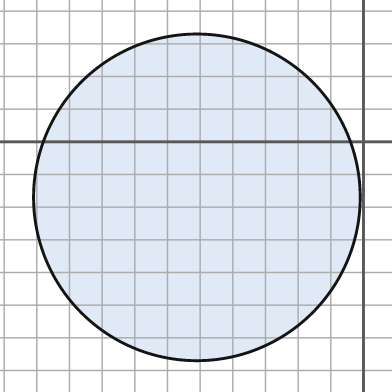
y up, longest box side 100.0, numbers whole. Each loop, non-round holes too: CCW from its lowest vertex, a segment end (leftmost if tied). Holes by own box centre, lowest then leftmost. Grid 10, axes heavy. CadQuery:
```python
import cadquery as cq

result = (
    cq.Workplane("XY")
    .moveTo(-51.0, -17.0)
    .circle(50.0)
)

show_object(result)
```